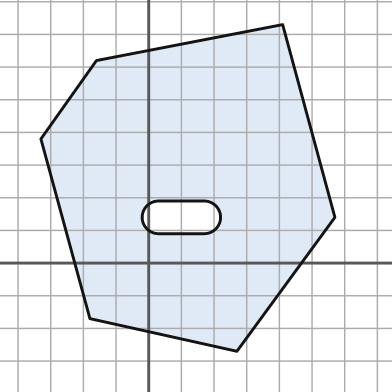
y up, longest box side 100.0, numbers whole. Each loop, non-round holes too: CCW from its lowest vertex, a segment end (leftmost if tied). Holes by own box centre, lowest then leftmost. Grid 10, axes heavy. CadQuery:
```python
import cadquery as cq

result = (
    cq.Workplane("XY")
    .moveTo(27.0, -27.0)
    .lineTo(57.0, 14.0)
    .lineTo(41.0, 73.0)
    .lineTo(-16.0, 62.0)
    .lineTo(-33.0, 38.0)
    .lineTo(-18.0, -17.0)
    .close()
    .moveTo(3.0, 9.0)
    .lineTo(17.0, 9.0)
    .threePointArc((22.0, 14.0), (17.0, 19.0))
    .lineTo(3.0, 19.0)
    .threePointArc((-2.0, 14.0), (3.0, 9.0))
    .close()
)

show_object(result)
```